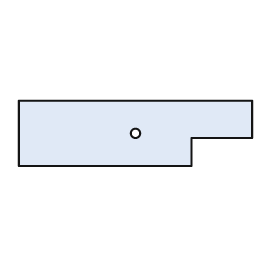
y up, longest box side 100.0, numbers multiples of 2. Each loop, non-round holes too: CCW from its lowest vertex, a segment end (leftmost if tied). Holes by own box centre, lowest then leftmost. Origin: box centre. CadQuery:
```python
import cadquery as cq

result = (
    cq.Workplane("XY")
    .moveTo(-50.0, -14.0)
    .lineTo(24.0, -14.0)
    .lineTo(24.0, -2.0)
    .lineTo(50.0, -2.0)
    .lineTo(50.0, 14.0)
    .lineTo(-50.0, 14.0)
    .close()
    .moveTo(0.0, 0.0)
    .circle(2.0)
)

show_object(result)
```